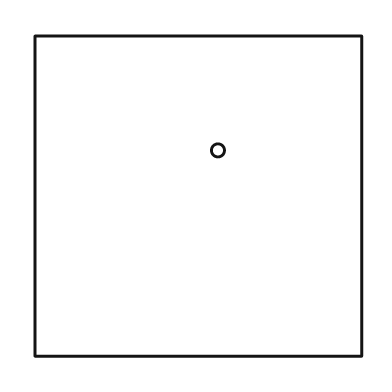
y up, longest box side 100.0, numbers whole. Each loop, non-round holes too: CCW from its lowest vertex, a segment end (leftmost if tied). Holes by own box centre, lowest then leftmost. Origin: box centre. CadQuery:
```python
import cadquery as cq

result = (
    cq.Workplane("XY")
    .moveTo(-50.0, -49.0)
    .lineTo(50.0, -49.0)
    .lineTo(50.0, 49.0)
    .lineTo(-50.0, 49.0)
    .close()
    .moveTo(6.0, 14.0)
    .circle(2.0)
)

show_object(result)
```